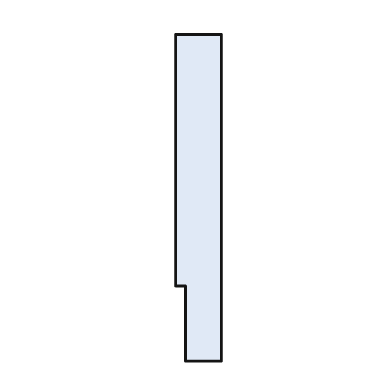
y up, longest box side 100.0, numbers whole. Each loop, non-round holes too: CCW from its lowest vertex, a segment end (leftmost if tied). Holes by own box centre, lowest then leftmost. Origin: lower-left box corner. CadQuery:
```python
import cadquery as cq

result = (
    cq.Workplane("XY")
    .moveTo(3.0, 0.0)
    .lineTo(14.0, 0.0)
    .lineTo(14.0, 100.0)
    .lineTo(0.0, 100.0)
    .lineTo(0.0, 23.0)
    .lineTo(3.0, 23.0)
    .close()
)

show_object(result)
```